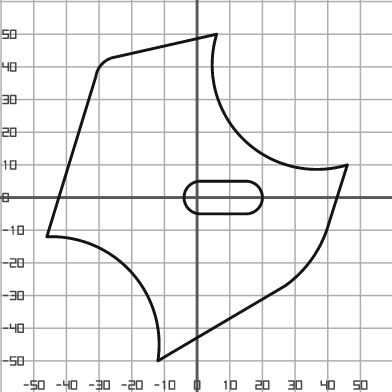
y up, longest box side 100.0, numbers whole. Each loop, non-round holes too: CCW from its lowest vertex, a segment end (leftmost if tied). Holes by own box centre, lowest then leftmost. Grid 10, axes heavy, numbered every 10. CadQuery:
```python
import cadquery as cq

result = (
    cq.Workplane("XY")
    .moveTo(-12.0, -50.0)
    .lineTo(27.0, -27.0)
    .threePointArc((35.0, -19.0), (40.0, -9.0))
    .lineTo(46.0, 10.0)
    .threePointArc((14.0, 18.0), (6.0, 50.0))
    .lineTo(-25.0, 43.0)
    .threePointArc((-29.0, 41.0), (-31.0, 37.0))
    .lineTo(-46.0, -12.0)
    .threePointArc((-20.0, -23.0), (-12.0, -50.0))
    .close()
    .moveTo(1.0, -5.0)
    .lineTo(15.0, -5.0)
    .threePointArc((20.0, 0.0), (15.0, 5.0))
    .lineTo(1.0, 5.0)
    .threePointArc((-4.0, 0.0), (1.0, -5.0))
    .close()
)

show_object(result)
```